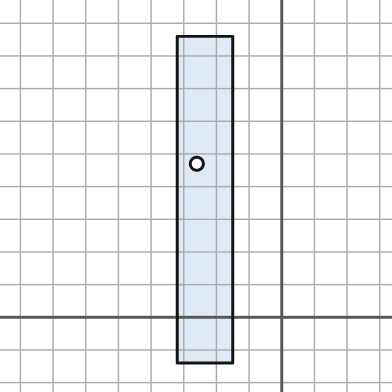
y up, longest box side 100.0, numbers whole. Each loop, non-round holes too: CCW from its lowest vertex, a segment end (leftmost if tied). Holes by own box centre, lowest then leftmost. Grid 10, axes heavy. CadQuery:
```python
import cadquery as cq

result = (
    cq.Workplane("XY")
    .moveTo(-32.0, -14.0)
    .lineTo(-15.0, -14.0)
    .lineTo(-15.0, 86.0)
    .lineTo(-32.0, 86.0)
    .close()
    .moveTo(-26.0, 47.0)
    .circle(2.0)
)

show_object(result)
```